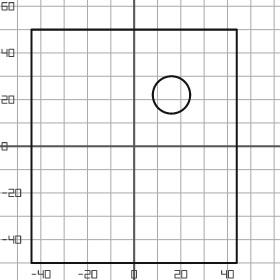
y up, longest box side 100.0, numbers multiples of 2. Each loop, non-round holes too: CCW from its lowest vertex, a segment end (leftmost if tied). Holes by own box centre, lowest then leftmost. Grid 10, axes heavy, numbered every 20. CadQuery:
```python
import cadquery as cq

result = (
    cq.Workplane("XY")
    .moveTo(-44.0, -50.0)
    .lineTo(44.0, -50.0)
    .lineTo(44.0, 50.0)
    .lineTo(-44.0, 50.0)
    .close()
    .moveTo(16.0, 22.0)
    .circle(8.0)
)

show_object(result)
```